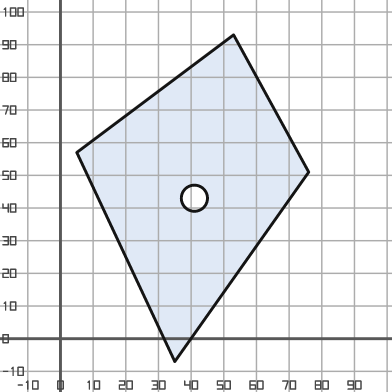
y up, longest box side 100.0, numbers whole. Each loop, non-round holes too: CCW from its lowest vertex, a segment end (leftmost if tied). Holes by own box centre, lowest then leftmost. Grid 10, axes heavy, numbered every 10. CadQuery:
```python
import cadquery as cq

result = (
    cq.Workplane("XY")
    .moveTo(35.0, -7.0)
    .lineTo(76.0, 51.0)
    .lineTo(53.0, 93.0)
    .lineTo(5.0, 57.0)
    .close()
    .moveTo(41.0, 43.0)
    .circle(4.0)
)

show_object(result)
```